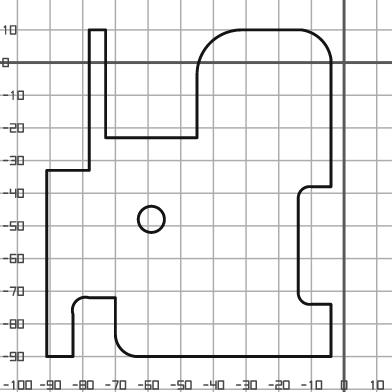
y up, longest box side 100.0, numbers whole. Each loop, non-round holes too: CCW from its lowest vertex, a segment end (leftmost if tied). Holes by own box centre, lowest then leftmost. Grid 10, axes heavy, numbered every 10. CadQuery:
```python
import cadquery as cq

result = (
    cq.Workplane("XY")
    .moveTo(-91.0, -90.0)
    .lineTo(-83.0, -90.0)
    .lineTo(-83.0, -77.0)
    .threePointArc((-82.0, -73.0), (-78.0, -72.0))
    .lineTo(-70.0, -72.0)
    .lineTo(-70.0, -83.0)
    .threePointArc((-68.0, -88.0), (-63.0, -90.0))
    .lineTo(-4.0, -90.0)
    .lineTo(-4.0, -74.0)
    .lineTo(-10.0, -74.0)
    .threePointArc((-13.0, -73.0), (-14.0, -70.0))
    .lineTo(-14.0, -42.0)
    .threePointArc((-13.0, -39.0), (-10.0, -38.0))
    .lineTo(-4.0, -38.0)
    .lineTo(-4.0, 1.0)
    .threePointArc((-7.0, 7.0), (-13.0, 10.0))
    .lineTo(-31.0, 10.0)
    .threePointArc((-41.0, 6.0), (-45.0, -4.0))
    .lineTo(-45.0, -23.0)
    .lineTo(-73.0, -23.0)
    .lineTo(-73.0, 10.0)
    .lineTo(-78.0, 10.0)
    .lineTo(-78.0, -33.0)
    .lineTo(-91.0, -33.0)
    .close()
    .moveTo(-59.0, -48.0)
    .circle(4.0)
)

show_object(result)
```